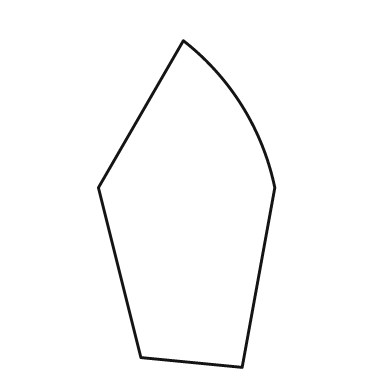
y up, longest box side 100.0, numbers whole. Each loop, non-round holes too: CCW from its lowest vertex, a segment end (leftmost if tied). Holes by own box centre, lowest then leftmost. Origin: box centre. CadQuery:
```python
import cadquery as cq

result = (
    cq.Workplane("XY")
    .moveTo(17.0, -50.0)
    .lineTo(27.0, 5.0)
    .threePointArc((17.0, 30.0), (-1.0, 50.0))
    .lineTo(-27.0, 5.0)
    .lineTo(-14.0, -47.0)
    .close()
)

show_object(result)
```